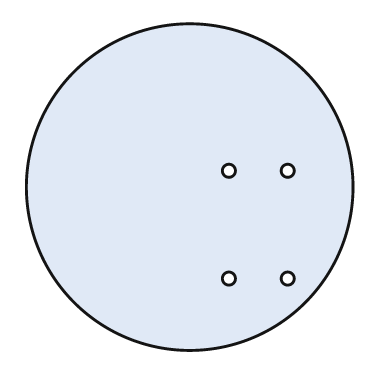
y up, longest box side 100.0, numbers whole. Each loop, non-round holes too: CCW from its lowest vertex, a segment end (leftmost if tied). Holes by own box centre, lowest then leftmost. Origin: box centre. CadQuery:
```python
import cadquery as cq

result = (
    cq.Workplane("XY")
    .moveTo(0.0, 0.0)
    .circle(50.0)
    .moveTo(12.0, -28.0)
    .circle(2.0)
    .moveTo(30.0, -28.0)
    .circle(2.0)
    .moveTo(12.0, 5.0)
    .circle(2.0)
    .moveTo(30.0, 5.0)
    .circle(2.0)
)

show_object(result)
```